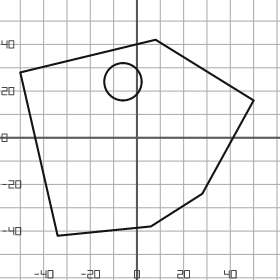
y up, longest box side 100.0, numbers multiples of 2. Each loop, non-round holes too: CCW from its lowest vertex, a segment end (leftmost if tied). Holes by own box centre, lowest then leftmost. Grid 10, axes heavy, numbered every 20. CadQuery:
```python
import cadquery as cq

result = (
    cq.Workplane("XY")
    .moveTo(-34.0, -42.0)
    .lineTo(6.0, -38.0)
    .lineTo(28.0, -24.0)
    .lineTo(50.0, 16.0)
    .lineTo(8.0, 42.0)
    .lineTo(-50.0, 28.0)
    .close()
    .moveTo(-6.0, 24.0)
    .circle(8.0)
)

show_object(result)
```